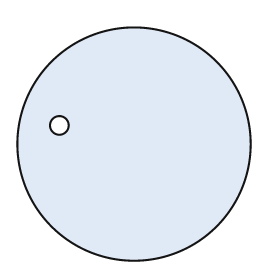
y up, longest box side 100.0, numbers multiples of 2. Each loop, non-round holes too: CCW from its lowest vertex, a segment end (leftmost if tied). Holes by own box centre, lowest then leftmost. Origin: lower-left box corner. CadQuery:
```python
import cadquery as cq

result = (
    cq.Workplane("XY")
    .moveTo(50.0, 50.0)
    .circle(50.0)
    .moveTo(18.0, 58.0)
    .circle(4.0)
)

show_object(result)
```